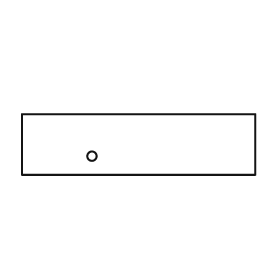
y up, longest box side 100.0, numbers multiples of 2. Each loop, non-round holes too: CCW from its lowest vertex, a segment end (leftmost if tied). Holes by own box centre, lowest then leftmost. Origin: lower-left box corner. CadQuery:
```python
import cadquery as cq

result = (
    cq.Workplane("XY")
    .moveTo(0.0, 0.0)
    .lineTo(100.0, 0.0)
    .lineTo(100.0, 26.0)
    .lineTo(0.0, 26.0)
    .close()
    .moveTo(30.0, 8.0)
    .circle(2.0)
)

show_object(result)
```